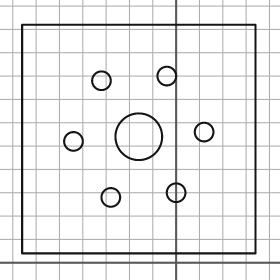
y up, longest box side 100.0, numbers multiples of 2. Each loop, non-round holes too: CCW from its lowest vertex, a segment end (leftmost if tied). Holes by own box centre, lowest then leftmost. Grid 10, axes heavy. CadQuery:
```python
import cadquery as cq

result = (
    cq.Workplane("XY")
    .moveTo(-66.0, 4.0)
    .lineTo(34.0, 4.0)
    .lineTo(34.0, 102.0)
    .lineTo(-66.0, 102.0)
    .close()
    .moveTo(-28.0, 28.0)
    .circle(4.0)
    .moveTo(0.0, 30.0)
    .circle(4.0)
    .moveTo(-44.0, 52.0)
    .circle(4.0)
    .moveTo(-16.0, 54.0)
    .circle(10.0)
    .moveTo(12.0, 56.0)
    .circle(4.0)
    .moveTo(-32.0, 78.0)
    .circle(4.0)
    .moveTo(-4.0, 80.0)
    .circle(4.0)
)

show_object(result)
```